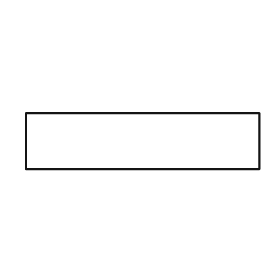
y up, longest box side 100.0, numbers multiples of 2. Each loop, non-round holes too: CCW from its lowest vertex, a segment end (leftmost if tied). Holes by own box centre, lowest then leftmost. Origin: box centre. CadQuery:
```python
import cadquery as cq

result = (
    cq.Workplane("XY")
    .moveTo(-50.0, -12.0)
    .lineTo(50.0, -12.0)
    .lineTo(50.0, 12.0)
    .lineTo(-50.0, 12.0)
    .close()
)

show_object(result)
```